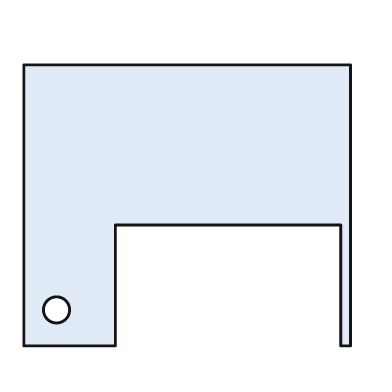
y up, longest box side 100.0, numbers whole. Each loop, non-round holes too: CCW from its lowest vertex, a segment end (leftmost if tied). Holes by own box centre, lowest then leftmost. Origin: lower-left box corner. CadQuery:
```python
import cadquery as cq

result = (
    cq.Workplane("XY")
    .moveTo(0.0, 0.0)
    .lineTo(28.0, 0.0)
    .lineTo(28.0, 37.0)
    .lineTo(97.0, 37.0)
    .lineTo(97.0, 0.0)
    .lineTo(100.0, 0.0)
    .lineTo(100.0, 86.0)
    .lineTo(0.0, 86.0)
    .close()
    .moveTo(10.0, 11.0)
    .circle(4.0)
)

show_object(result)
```